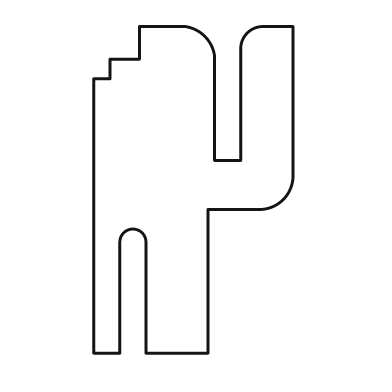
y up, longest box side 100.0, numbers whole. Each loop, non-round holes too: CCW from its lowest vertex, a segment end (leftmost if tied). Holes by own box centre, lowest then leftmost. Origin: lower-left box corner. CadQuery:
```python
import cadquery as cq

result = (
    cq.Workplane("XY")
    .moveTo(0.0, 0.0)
    .lineTo(8.0, 0.0)
    .lineTo(8.0, 34.0)
    .threePointArc((12.0, 38.0), (16.0, 34.0))
    .lineTo(16.0, 0.0)
    .lineTo(35.0, 0.0)
    .lineTo(35.0, 44.0)
    .lineTo(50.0, 44.0)
    .threePointArc((58.0, 47.0), (61.0, 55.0))
    .lineTo(61.0, 100.0)
    .lineTo(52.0, 100.0)
    .threePointArc((47.0, 98.0), (45.0, 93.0))
    .lineTo(45.0, 59.0)
    .lineTo(37.0, 59.0)
    .lineTo(37.0, 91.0)
    .threePointArc((34.0, 97.0), (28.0, 100.0))
    .lineTo(14.0, 100.0)
    .lineTo(14.0, 90.0)
    .lineTo(5.0, 90.0)
    .lineTo(5.0, 84.0)
    .lineTo(0.0, 84.0)
    .close()
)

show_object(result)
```